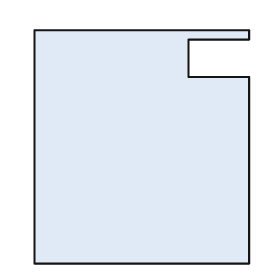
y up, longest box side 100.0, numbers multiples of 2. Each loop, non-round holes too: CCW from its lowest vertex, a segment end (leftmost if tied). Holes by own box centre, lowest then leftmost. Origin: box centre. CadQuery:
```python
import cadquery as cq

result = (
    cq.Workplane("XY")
    .moveTo(-46.0, -50.0)
    .lineTo(46.0, -50.0)
    .lineTo(46.0, 30.0)
    .lineTo(20.0, 30.0)
    .lineTo(20.0, 46.0)
    .lineTo(46.0, 46.0)
    .lineTo(46.0, 50.0)
    .lineTo(-46.0, 50.0)
    .close()
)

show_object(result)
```